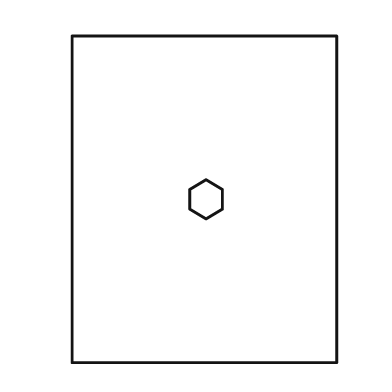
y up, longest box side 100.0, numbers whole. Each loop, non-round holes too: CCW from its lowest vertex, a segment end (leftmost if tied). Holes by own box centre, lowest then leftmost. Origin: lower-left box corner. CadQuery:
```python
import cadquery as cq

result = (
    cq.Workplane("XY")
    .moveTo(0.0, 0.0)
    .lineTo(81.0, 0.0)
    .lineTo(81.0, 100.0)
    .lineTo(0.0, 100.0)
    .close()
    .moveTo(41.0, 44.0)
    .lineTo(46.0, 47.0)
    .lineTo(46.0, 53.0)
    .lineTo(41.0, 56.0)
    .lineTo(36.0, 53.0)
    .lineTo(36.0, 47.0)
    .close()
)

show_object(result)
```